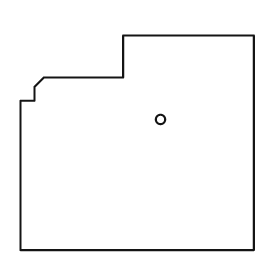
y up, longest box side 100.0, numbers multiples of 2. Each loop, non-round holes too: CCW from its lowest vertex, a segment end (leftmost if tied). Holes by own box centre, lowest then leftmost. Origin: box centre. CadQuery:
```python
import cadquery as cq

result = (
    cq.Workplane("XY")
    .moveTo(-50.0, -46.0)
    .lineTo(50.0, -46.0)
    .lineTo(50.0, 46.0)
    .lineTo(-6.0, 46.0)
    .lineTo(-6.0, 28.0)
    .lineTo(-40.0, 28.0)
    .lineTo(-44.0, 24.0)
    .lineTo(-44.0, 18.0)
    .lineTo(-50.0, 18.0)
    .close()
    .moveTo(10.0, 10.0)
    .circle(2.0)
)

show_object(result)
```